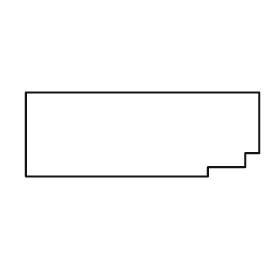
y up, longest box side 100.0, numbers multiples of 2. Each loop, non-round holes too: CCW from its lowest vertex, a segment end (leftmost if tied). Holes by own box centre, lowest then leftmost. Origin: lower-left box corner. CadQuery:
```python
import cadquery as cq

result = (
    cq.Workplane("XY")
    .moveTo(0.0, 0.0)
    .lineTo(78.0, 0.0)
    .lineTo(78.0, 4.0)
    .lineTo(94.0, 4.0)
    .lineTo(94.0, 10.0)
    .lineTo(100.0, 10.0)
    .lineTo(100.0, 36.0)
    .lineTo(0.0, 36.0)
    .close()
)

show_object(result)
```